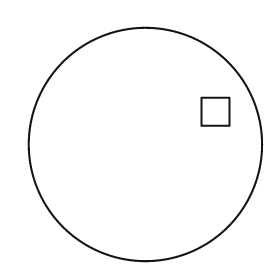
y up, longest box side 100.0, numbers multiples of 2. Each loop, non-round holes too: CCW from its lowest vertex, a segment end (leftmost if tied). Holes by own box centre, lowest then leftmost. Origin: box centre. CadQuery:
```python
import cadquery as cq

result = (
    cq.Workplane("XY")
    .moveTo(0.0, 0.0)
    .circle(50.0)
    .moveTo(24.0, 8.0)
    .lineTo(36.0, 8.0)
    .lineTo(36.0, 20.0)
    .lineTo(24.0, 20.0)
    .close()
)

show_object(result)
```